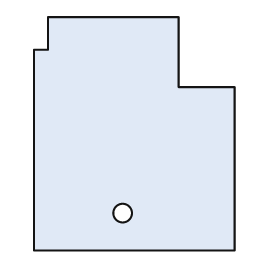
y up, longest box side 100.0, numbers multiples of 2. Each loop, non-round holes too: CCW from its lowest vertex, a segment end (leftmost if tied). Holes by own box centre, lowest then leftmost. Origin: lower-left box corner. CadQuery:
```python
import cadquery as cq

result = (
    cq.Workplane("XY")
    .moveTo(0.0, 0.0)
    .lineTo(86.0, 0.0)
    .lineTo(86.0, 70.0)
    .lineTo(62.0, 70.0)
    .lineTo(62.0, 100.0)
    .lineTo(6.0, 100.0)
    .lineTo(6.0, 86.0)
    .lineTo(0.0, 86.0)
    .close()
    .moveTo(38.0, 16.0)
    .circle(4.0)
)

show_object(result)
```